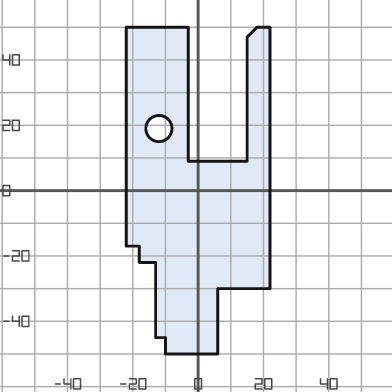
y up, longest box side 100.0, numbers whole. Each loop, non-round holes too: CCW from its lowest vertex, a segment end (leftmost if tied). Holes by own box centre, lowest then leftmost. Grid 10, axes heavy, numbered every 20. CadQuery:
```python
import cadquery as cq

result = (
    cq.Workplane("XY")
    .moveTo(-10.0, -50.0)
    .lineTo(6.0, -50.0)
    .lineTo(6.0, -30.0)
    .lineTo(22.0, -30.0)
    .lineTo(22.0, 50.0)
    .lineTo(18.0, 50.0)
    .lineTo(15.0, 47.0)
    .lineTo(15.0, 9.0)
    .lineTo(-3.0, 9.0)
    .lineTo(-3.0, 50.0)
    .lineTo(-22.0, 50.0)
    .lineTo(-22.0, -17.0)
    .lineTo(-18.0, -17.0)
    .lineTo(-18.0, -22.0)
    .lineTo(-13.0, -22.0)
    .lineTo(-13.0, -45.0)
    .lineTo(-10.0, -45.0)
    .close()
    .moveTo(-12.0, 19.0)
    .circle(4.0)
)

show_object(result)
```